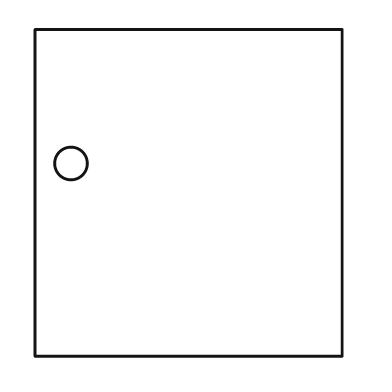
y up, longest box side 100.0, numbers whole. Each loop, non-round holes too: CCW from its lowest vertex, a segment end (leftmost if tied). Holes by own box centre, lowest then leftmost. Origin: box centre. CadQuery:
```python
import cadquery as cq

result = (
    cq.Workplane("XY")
    .moveTo(-47.0, -50.0)
    .lineTo(47.0, -50.0)
    .lineTo(47.0, 50.0)
    .lineTo(-47.0, 50.0)
    .close()
    .moveTo(-36.0, 9.0)
    .circle(5.0)
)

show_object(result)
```